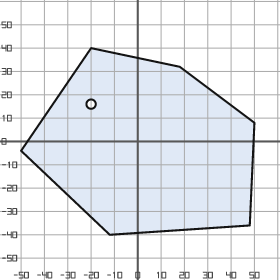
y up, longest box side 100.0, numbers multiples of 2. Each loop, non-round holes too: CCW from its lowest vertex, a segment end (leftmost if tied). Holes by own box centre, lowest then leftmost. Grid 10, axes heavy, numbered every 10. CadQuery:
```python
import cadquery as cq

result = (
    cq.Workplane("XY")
    .moveTo(-12.0, -40.0)
    .lineTo(48.0, -36.0)
    .lineTo(50.0, 8.0)
    .lineTo(18.0, 32.0)
    .lineTo(-20.0, 40.0)
    .lineTo(-50.0, -4.0)
    .close()
    .moveTo(-20.0, 16.0)
    .circle(2.0)
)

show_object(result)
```